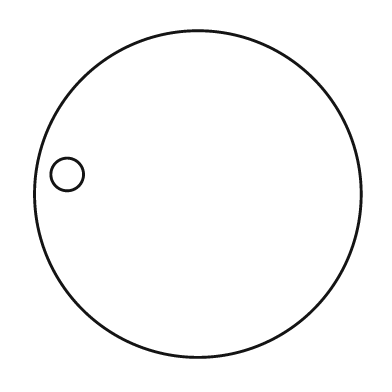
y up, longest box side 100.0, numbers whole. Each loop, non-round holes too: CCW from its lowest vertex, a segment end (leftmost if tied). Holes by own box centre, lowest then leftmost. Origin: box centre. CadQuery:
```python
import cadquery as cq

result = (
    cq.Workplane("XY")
    .moveTo(0.0, 0.0)
    .circle(50.0)
    .moveTo(-40.0, 6.0)
    .circle(5.0)
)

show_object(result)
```